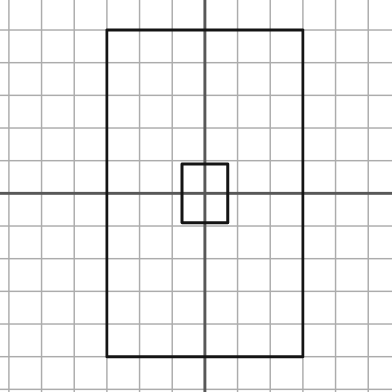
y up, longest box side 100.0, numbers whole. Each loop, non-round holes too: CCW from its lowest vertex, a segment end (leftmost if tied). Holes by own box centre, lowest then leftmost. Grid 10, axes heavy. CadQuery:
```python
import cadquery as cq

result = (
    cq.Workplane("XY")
    .moveTo(-30.0, -50.0)
    .lineTo(30.0, -50.0)
    .lineTo(30.0, 50.0)
    .lineTo(-30.0, 50.0)
    .close()
    .moveTo(-7.0, -9.0)
    .lineTo(7.0, -9.0)
    .lineTo(7.0, 9.0)
    .lineTo(-7.0, 9.0)
    .close()
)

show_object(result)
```